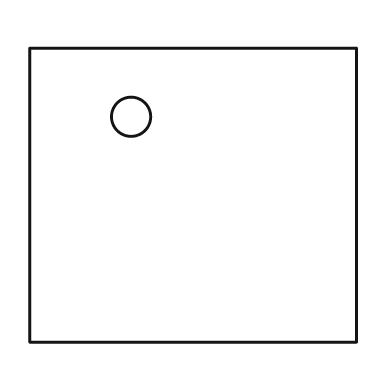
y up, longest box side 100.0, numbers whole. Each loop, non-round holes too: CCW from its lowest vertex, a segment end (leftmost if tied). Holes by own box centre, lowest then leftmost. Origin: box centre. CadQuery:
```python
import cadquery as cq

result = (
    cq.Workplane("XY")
    .moveTo(-50.0, -45.0)
    .lineTo(50.0, -45.0)
    .lineTo(50.0, 45.0)
    .lineTo(-50.0, 45.0)
    .close()
    .moveTo(-19.0, 24.0)
    .circle(6.0)
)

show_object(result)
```